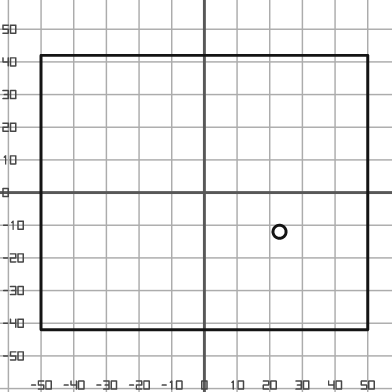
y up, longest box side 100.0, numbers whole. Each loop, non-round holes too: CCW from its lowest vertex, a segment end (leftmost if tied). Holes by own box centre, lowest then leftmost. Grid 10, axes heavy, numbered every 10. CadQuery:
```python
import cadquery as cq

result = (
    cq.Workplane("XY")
    .moveTo(-50.0, -42.0)
    .lineTo(50.0, -42.0)
    .lineTo(50.0, 42.0)
    .lineTo(-50.0, 42.0)
    .close()
    .moveTo(23.0, -12.0)
    .circle(2.0)
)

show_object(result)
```